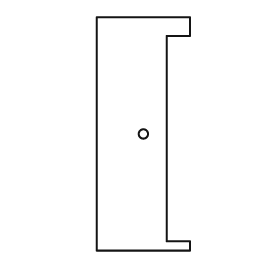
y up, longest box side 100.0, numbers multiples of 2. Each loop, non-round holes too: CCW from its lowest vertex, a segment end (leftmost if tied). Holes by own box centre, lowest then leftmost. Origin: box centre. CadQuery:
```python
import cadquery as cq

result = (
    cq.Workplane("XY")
    .moveTo(-20.0, -50.0)
    .lineTo(20.0, -50.0)
    .lineTo(20.0, -46.0)
    .lineTo(10.0, -46.0)
    .lineTo(10.0, 42.0)
    .lineTo(20.0, 42.0)
    .lineTo(20.0, 50.0)
    .lineTo(-20.0, 50.0)
    .close()
    .moveTo(0.0, 0.0)
    .circle(2.0)
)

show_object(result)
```